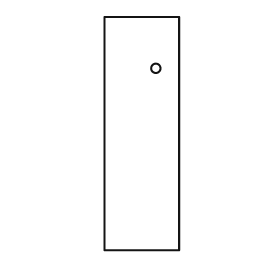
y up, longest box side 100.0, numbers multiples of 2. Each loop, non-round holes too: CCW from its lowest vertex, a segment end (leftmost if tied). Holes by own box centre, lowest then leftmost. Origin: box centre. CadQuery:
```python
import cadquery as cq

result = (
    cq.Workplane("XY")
    .moveTo(-16.0, -50.0)
    .lineTo(16.0, -50.0)
    .lineTo(16.0, 50.0)
    .lineTo(-16.0, 50.0)
    .close()
    .moveTo(6.0, 28.0)
    .circle(2.0)
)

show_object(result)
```